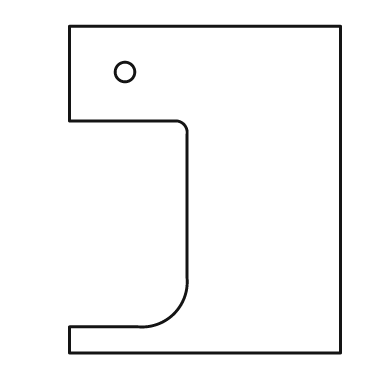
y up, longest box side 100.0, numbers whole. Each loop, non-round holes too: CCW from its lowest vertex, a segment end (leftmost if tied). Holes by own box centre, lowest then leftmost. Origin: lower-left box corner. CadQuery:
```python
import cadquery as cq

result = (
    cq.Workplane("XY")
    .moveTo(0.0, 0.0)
    .lineTo(83.0, 0.0)
    .lineTo(83.0, 100.0)
    .lineTo(0.0, 100.0)
    .lineTo(0.0, 71.0)
    .lineTo(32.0, 71.0)
    .threePointArc((35.0, 70.0), (36.0, 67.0))
    .lineTo(36.0, 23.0)
    .threePointArc((32.0, 12.0), (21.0, 8.0))
    .lineTo(0.0, 8.0)
    .close()
    .moveTo(17.0, 86.0)
    .circle(3.0)
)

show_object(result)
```